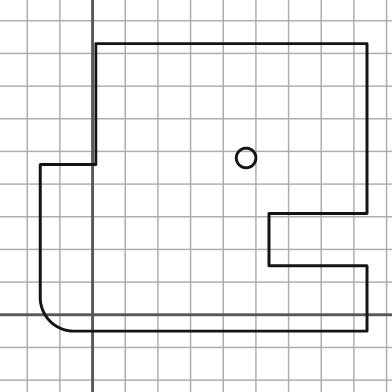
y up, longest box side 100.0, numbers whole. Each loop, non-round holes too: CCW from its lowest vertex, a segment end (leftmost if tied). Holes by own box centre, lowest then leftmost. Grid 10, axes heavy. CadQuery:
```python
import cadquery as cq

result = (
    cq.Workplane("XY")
    .moveTo(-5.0, -5.0)
    .lineTo(84.0, -5.0)
    .lineTo(84.0, 15.0)
    .lineTo(54.0, 15.0)
    .lineTo(54.0, 31.0)
    .lineTo(84.0, 31.0)
    .lineTo(84.0, 83.0)
    .lineTo(1.0, 83.0)
    .lineTo(1.0, 46.0)
    .lineTo(-16.0, 46.0)
    .lineTo(-16.0, 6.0)
    .threePointArc((-13.0, -2.0), (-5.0, -5.0))
    .close()
    .moveTo(47.0, 48.0)
    .circle(3.0)
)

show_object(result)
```